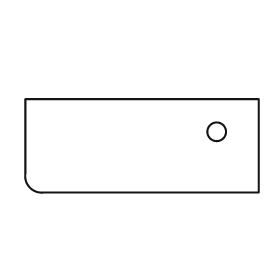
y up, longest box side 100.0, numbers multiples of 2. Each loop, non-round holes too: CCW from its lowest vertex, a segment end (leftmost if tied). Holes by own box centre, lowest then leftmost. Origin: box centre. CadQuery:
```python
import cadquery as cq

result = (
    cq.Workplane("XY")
    .moveTo(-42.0, -20.0)
    .lineTo(50.0, -20.0)
    .lineTo(50.0, 20.0)
    .lineTo(-50.0, 20.0)
    .lineTo(-50.0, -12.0)
    .threePointArc((-48.0, -18.0), (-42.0, -20.0))
    .close()
    .moveTo(32.0, 6.0)
    .circle(4.0)
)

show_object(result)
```